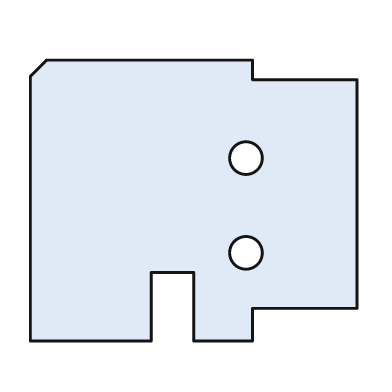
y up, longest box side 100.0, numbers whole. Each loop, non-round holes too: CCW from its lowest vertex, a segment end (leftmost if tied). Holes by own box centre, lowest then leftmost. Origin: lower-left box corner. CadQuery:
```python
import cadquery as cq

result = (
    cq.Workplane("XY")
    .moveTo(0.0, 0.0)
    .lineTo(37.0, 0.0)
    .lineTo(37.0, 21.0)
    .lineTo(50.0, 21.0)
    .lineTo(50.0, 0.0)
    .lineTo(68.0, 0.0)
    .lineTo(68.0, 10.0)
    .lineTo(100.0, 10.0)
    .lineTo(100.0, 80.0)
    .lineTo(68.0, 80.0)
    .lineTo(68.0, 86.0)
    .lineTo(5.0, 86.0)
    .lineTo(0.0, 81.0)
    .close()
    .moveTo(66.0, 27.0)
    .circle(5.0)
    .moveTo(66.0, 56.0)
    .circle(5.0)
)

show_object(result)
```